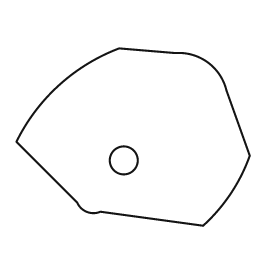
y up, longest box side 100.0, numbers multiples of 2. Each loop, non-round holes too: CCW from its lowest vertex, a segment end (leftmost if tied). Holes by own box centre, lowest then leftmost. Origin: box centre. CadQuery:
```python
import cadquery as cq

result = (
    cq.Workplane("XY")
    .moveTo(30.0, -38.0)
    .threePointArc((42.0, -24.0), (50.0, -8.0))
    .lineTo(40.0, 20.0)
    .threePointArc((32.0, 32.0), (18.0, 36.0))
    .lineTo(-6.0, 38.0)
    .threePointArc((-32.0, 22.0), (-50.0, -2.0))
    .lineTo(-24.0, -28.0)
    .threePointArc((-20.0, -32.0), (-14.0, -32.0))
    .close()
    .moveTo(-4.0, -10.0)
    .circle(6.0)
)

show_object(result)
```